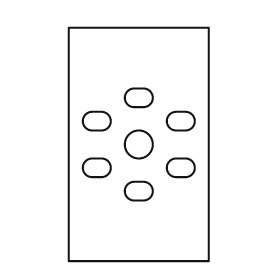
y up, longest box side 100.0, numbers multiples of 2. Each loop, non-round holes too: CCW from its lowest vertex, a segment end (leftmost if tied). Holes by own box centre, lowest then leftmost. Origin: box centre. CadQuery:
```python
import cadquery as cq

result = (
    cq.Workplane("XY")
    .moveTo(-30.0, -50.0)
    .lineTo(30.0, -50.0)
    .lineTo(30.0, 50.0)
    .lineTo(-30.0, 50.0)
    .close()
    .moveTo(-2.0, -24.0)
    .lineTo(2.0, -24.0)
    .threePointArc((6.0, -20.0), (2.0, -16.0))
    .lineTo(-2.0, -16.0)
    .threePointArc((-6.0, -20.0), (-2.0, -24.0))
    .close()
    .moveTo(-20.0, -14.0)
    .lineTo(-16.0, -14.0)
    .threePointArc((-12.0, -10.0), (-16.0, -6.0))
    .lineTo(-20.0, -6.0)
    .threePointArc((-24.0, -10.0), (-20.0, -14.0))
    .close()
    .moveTo(16.0, -14.0)
    .lineTo(20.0, -14.0)
    .threePointArc((24.0, -10.0), (20.0, -6.0))
    .lineTo(16.0, -6.0)
    .threePointArc((12.0, -10.0), (16.0, -14.0))
    .close()
    .moveTo(0.0, 0.0)
    .circle(6.0)
    .moveTo(-20.0, 6.0)
    .lineTo(-16.0, 6.0)
    .threePointArc((-12.0, 10.0), (-16.0, 14.0))
    .lineTo(-20.0, 14.0)
    .threePointArc((-24.0, 10.0), (-20.0, 6.0))
    .close()
    .moveTo(16.0, 6.0)
    .lineTo(20.0, 6.0)
    .threePointArc((24.0, 10.0), (20.0, 14.0))
    .lineTo(16.0, 14.0)
    .threePointArc((12.0, 10.0), (16.0, 6.0))
    .close()
    .moveTo(-2.0, 16.0)
    .lineTo(2.0, 16.0)
    .threePointArc((6.0, 20.0), (2.0, 24.0))
    .lineTo(-2.0, 24.0)
    .threePointArc((-6.0, 20.0), (-2.0, 16.0))
    .close()
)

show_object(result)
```